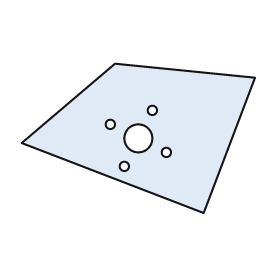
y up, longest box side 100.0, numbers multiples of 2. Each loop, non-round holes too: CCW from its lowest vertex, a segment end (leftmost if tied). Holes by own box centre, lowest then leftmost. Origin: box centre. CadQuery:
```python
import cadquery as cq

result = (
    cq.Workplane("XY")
    .moveTo(28.0, -32.0)
    .lineTo(50.0, 26.0)
    .lineTo(-10.0, 32.0)
    .lineTo(-50.0, -2.0)
    .close()
    .moveTo(-6.0, -12.0)
    .circle(2.0)
    .moveTo(12.0, -6.0)
    .circle(2.0)
    .moveTo(0.0, 0.0)
    .circle(6.0)
    .moveTo(-12.0, 6.0)
    .circle(2.0)
    .moveTo(6.0, 12.0)
    .circle(2.0)
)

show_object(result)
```